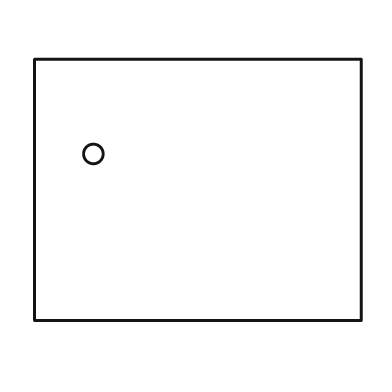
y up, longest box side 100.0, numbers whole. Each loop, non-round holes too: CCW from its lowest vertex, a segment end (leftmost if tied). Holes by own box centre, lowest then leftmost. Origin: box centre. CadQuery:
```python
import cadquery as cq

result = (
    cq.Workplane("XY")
    .moveTo(-50.0, -40.0)
    .lineTo(50.0, -40.0)
    .lineTo(50.0, 40.0)
    .lineTo(-50.0, 40.0)
    .close()
    .moveTo(-32.0, 11.0)
    .circle(3.0)
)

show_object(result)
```